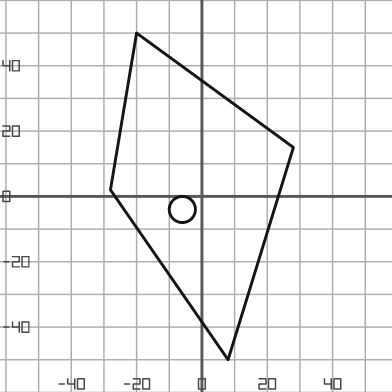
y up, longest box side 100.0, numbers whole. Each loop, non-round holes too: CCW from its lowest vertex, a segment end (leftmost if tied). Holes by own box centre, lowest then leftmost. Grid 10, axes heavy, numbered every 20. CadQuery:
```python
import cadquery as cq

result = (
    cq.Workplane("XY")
    .moveTo(8.0, -50.0)
    .lineTo(28.0, 15.0)
    .lineTo(-20.0, 50.0)
    .lineTo(-28.0, 2.0)
    .close()
    .moveTo(-6.0, -4.0)
    .circle(4.0)
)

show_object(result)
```